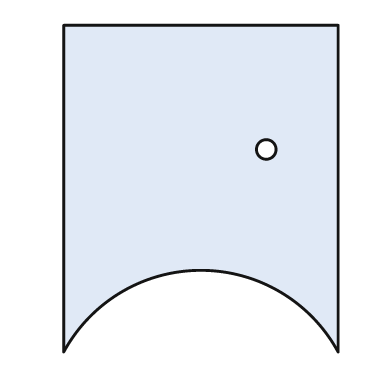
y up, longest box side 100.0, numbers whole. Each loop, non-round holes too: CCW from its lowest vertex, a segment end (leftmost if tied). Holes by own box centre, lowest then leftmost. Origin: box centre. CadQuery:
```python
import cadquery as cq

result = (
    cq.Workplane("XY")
    .moveTo(-42.0, -50.0)
    .threePointArc((0.0, -25.0), (42.0, -50.0))
    .lineTo(42.0, 50.0)
    .lineTo(-42.0, 50.0)
    .close()
    .moveTo(20.0, 12.0)
    .circle(3.0)
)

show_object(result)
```